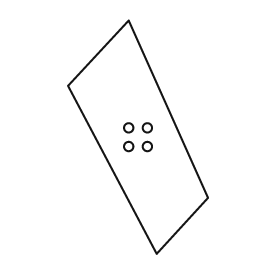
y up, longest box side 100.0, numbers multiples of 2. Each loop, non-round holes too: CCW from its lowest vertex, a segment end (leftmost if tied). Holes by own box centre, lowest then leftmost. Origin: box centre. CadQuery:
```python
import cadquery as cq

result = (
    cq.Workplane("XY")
    .moveTo(8.0, -50.0)
    .lineTo(30.0, -26.0)
    .lineTo(-4.0, 50.0)
    .lineTo(-30.0, 22.0)
    .close()
    .moveTo(-4.0, -4.0)
    .circle(2.0)
    .moveTo(4.0, -4.0)
    .circle(2.0)
    .moveTo(-4.0, 4.0)
    .circle(2.0)
    .moveTo(4.0, 4.0)
    .circle(2.0)
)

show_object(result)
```